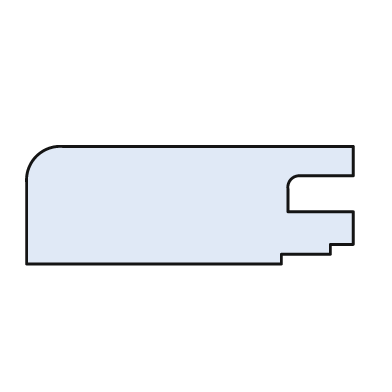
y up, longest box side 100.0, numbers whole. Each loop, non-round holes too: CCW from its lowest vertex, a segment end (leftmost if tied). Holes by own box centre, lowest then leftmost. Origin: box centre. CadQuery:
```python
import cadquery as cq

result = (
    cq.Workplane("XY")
    .moveTo(-50.0, -18.0)
    .lineTo(28.0, -18.0)
    .lineTo(28.0, -15.0)
    .lineTo(43.0, -15.0)
    .lineTo(43.0, -12.0)
    .lineTo(50.0, -12.0)
    .lineTo(50.0, -2.0)
    .lineTo(30.0, -2.0)
    .lineTo(30.0, 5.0)
    .threePointArc((31.0, 8.0), (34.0, 9.0))
    .lineTo(50.0, 9.0)
    .lineTo(50.0, 18.0)
    .lineTo(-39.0, 18.0)
    .threePointArc((-47.0, 15.0), (-50.0, 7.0))
    .close()
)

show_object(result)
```